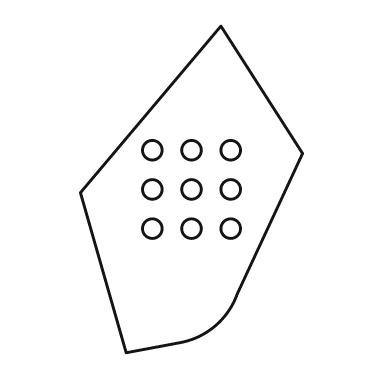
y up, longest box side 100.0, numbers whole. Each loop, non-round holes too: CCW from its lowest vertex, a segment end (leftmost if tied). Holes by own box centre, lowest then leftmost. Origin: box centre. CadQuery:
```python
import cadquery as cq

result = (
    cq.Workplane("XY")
    .moveTo(-20.0, -50.0)
    .lineTo(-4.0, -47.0)
    .threePointArc((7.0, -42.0), (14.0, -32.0))
    .lineTo(34.0, 11.0)
    .lineTo(9.0, 50.0)
    .lineTo(-34.0, -1.0)
    .close()
    .moveTo(-12.0, -12.0)
    .circle(3.0)
    .moveTo(0.0, -12.0)
    .circle(3.0)
    .moveTo(12.0, -12.0)
    .circle(3.0)
    .moveTo(-12.0, 0.0)
    .circle(3.0)
    .moveTo(0.0, 0.0)
    .circle(3.0)
    .moveTo(12.0, 0.0)
    .circle(3.0)
    .moveTo(-12.0, 12.0)
    .circle(3.0)
    .moveTo(0.0, 12.0)
    .circle(3.0)
    .moveTo(12.0, 12.0)
    .circle(3.0)
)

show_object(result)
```